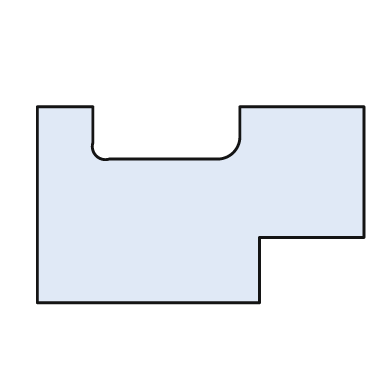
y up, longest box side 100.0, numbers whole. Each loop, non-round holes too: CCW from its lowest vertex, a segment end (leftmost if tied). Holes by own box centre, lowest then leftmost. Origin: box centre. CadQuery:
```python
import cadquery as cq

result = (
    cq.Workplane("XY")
    .moveTo(-50.0, -30.0)
    .lineTo(18.0, -30.0)
    .lineTo(18.0, -10.0)
    .lineTo(50.0, -10.0)
    .lineTo(50.0, 30.0)
    .lineTo(12.0, 30.0)
    .lineTo(12.0, 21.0)
    .threePointArc((10.0, 16.0), (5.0, 14.0))
    .lineTo(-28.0, 14.0)
    .threePointArc((-32.0, 15.0), (-33.0, 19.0))
    .lineTo(-33.0, 30.0)
    .lineTo(-50.0, 30.0)
    .close()
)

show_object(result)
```